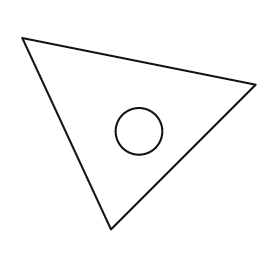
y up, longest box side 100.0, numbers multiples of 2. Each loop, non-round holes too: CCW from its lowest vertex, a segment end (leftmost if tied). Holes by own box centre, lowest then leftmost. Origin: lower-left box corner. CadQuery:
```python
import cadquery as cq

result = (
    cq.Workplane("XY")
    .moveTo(38.0, 0.0)
    .lineTo(100.0, 62.0)
    .lineTo(0.0, 82.0)
    .close()
    .moveTo(50.0, 42.0)
    .circle(10.0)
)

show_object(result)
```